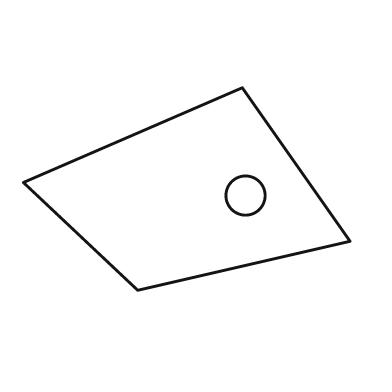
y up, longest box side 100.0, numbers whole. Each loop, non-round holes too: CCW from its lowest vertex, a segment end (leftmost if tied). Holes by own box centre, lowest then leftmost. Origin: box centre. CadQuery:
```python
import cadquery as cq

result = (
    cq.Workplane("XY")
    .moveTo(-15.0, -31.0)
    .lineTo(50.0, -16.0)
    .lineTo(17.0, 31.0)
    .lineTo(-50.0, 2.0)
    .close()
    .moveTo(18.0, -2.0)
    .circle(6.0)
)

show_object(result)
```